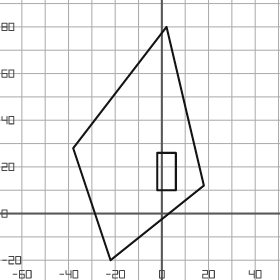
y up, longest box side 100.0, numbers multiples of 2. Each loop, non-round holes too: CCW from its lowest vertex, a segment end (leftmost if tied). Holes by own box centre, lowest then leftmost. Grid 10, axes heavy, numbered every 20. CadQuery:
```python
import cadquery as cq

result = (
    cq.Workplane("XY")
    .moveTo(-22.0, -20.0)
    .lineTo(18.0, 12.0)
    .lineTo(2.0, 80.0)
    .lineTo(-38.0, 28.0)
    .close()
    .moveTo(-2.0, 10.0)
    .lineTo(6.0, 10.0)
    .lineTo(6.0, 26.0)
    .lineTo(-2.0, 26.0)
    .close()
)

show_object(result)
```